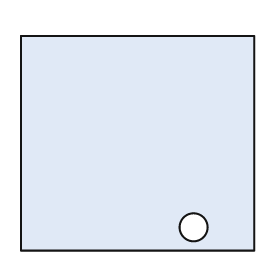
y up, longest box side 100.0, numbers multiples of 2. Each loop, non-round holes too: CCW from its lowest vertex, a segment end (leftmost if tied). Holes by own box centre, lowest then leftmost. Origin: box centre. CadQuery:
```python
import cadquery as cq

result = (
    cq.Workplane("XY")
    .moveTo(-50.0, -46.0)
    .lineTo(50.0, -46.0)
    .lineTo(50.0, 46.0)
    .lineTo(-50.0, 46.0)
    .close()
    .moveTo(24.0, -36.0)
    .circle(6.0)
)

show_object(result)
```